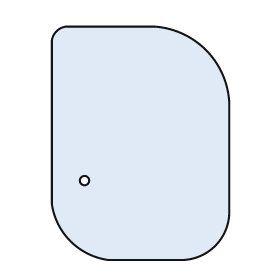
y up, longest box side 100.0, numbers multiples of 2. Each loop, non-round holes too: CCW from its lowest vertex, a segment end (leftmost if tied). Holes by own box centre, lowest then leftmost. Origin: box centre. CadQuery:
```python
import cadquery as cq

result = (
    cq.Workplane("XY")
    .moveTo(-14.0, -50.0)
    .lineTo(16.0, -50.0)
    .threePointArc((32.0, -44.0), (38.0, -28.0))
    .lineTo(38.0, 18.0)
    .threePointArc((28.0, 40.0), (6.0, 50.0))
    .lineTo(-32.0, 50.0)
    .threePointArc((-36.0, 48.0), (-38.0, 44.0))
    .lineTo(-38.0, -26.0)
    .threePointArc((-30.0, -42.0), (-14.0, -50.0))
    .close()
    .moveTo(-24.0, -16.0)
    .circle(2.0)
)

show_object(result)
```